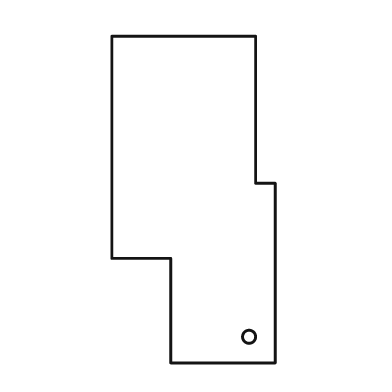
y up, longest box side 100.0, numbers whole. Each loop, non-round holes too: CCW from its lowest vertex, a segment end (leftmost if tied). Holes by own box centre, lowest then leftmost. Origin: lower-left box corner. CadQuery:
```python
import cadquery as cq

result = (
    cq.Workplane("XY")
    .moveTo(18.0, 0.0)
    .lineTo(50.0, 0.0)
    .lineTo(50.0, 55.0)
    .lineTo(44.0, 55.0)
    .lineTo(44.0, 100.0)
    .lineTo(0.0, 100.0)
    .lineTo(0.0, 32.0)
    .lineTo(18.0, 32.0)
    .close()
    .moveTo(42.0, 8.0)
    .circle(2.0)
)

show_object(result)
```